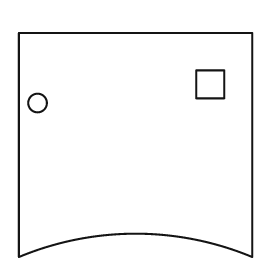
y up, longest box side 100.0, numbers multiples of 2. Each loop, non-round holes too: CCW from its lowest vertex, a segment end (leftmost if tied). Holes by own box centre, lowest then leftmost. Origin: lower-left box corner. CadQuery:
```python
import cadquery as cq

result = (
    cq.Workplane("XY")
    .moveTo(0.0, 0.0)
    .threePointArc((50.0, 10.0), (100.0, 0.0))
    .lineTo(100.0, 96.0)
    .lineTo(0.0, 96.0)
    .close()
    .moveTo(8.0, 66.0)
    .circle(4.0)
    .moveTo(76.0, 68.0)
    .lineTo(88.0, 68.0)
    .lineTo(88.0, 80.0)
    .lineTo(76.0, 80.0)
    .close()
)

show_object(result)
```